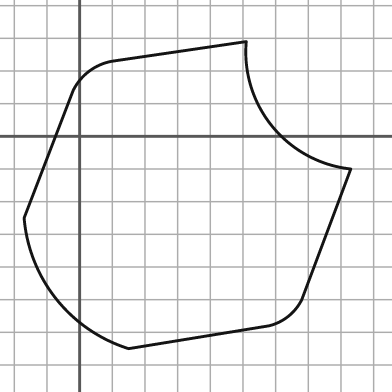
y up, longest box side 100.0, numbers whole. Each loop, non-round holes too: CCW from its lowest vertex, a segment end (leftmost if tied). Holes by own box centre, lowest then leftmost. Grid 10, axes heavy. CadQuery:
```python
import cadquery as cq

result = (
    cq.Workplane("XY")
    .moveTo(15.0, -65.0)
    .lineTo(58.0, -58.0)
    .threePointArc((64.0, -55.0), (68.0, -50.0))
    .lineTo(83.0, -10.0)
    .threePointArc((59.0, 3.0), (51.0, 29.0))
    .lineTo(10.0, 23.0)
    .threePointArc((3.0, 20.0), (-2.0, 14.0))
    .lineTo(-17.0, -25.0)
    .threePointArc((-7.0, -50.0), (15.0, -65.0))
    .close()
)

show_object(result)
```